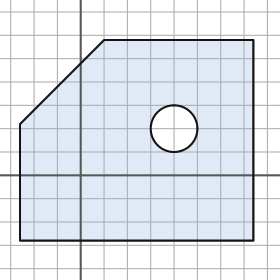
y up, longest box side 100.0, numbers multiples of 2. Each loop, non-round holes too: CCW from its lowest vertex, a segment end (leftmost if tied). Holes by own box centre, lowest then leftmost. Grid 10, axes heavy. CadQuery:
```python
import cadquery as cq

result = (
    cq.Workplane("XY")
    .moveTo(-26.0, -28.0)
    .lineTo(74.0, -28.0)
    .lineTo(74.0, 58.0)
    .lineTo(10.0, 58.0)
    .lineTo(-26.0, 22.0)
    .close()
    .moveTo(40.0, 20.0)
    .circle(10.0)
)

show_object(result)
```